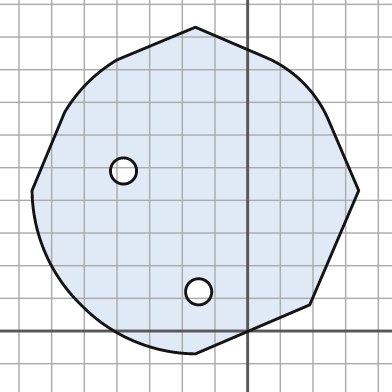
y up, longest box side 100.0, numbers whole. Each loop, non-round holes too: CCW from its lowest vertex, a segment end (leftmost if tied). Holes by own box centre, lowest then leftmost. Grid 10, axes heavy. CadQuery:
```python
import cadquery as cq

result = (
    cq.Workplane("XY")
    .moveTo(-16.0, -7.0)
    .lineTo(19.0, 8.0)
    .lineTo(34.0, 43.0)
    .lineTo(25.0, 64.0)
    .threePointArc((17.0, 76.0), (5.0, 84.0))
    .lineTo(-16.0, 93.0)
    .lineTo(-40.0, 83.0)
    .threePointArc((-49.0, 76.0), (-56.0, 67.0))
    .lineTo(-66.0, 43.0)
    .threePointArc((-62.0, 24.0), (-51.0, 8.0))
    .threePointArc((-35.0, -3.0), (-16.0, -7.0))
    .close()
    .moveTo(-15.0, 12.0)
    .circle(4.0)
    .moveTo(-38.0, 49.0)
    .circle(4.0)
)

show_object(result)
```